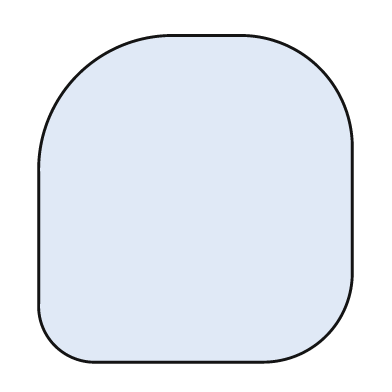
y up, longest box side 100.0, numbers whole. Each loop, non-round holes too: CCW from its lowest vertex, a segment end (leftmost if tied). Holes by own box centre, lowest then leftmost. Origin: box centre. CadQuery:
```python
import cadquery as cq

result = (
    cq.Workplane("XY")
    .moveTo(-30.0, -50.0)
    .lineTo(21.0, -50.0)
    .threePointArc((40.0, -42.0), (48.0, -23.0))
    .lineTo(48.0, 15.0)
    .threePointArc((38.0, 40.0), (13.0, 50.0))
    .lineTo(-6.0, 50.0)
    .threePointArc((-36.0, 38.0), (-48.0, 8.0))
    .lineTo(-48.0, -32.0)
    .threePointArc((-43.0, -45.0), (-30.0, -50.0))
    .close()
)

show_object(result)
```